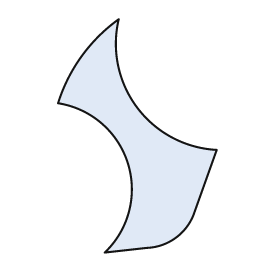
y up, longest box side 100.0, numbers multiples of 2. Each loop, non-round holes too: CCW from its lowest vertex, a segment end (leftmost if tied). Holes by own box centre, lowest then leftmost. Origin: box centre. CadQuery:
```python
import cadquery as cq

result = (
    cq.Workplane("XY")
    .moveTo(-14.0, -50.0)
    .lineTo(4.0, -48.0)
    .threePointArc((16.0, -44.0), (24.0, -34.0))
    .lineTo(34.0, -6.0)
    .threePointArc((0.0, 12.0), (-8.0, 50.0))
    .threePointArc((-24.0, 34.0), (-34.0, 14.0))
    .threePointArc((-4.0, -12.0), (-14.0, -50.0))
    .close()
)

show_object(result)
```